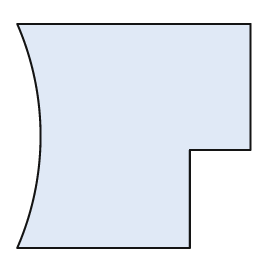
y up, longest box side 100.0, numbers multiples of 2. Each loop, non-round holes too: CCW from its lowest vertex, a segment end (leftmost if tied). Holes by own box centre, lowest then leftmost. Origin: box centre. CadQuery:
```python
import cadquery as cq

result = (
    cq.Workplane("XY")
    .moveTo(-50.0, -48.0)
    .lineTo(24.0, -48.0)
    .lineTo(24.0, -6.0)
    .lineTo(50.0, -6.0)
    .lineTo(50.0, 48.0)
    .lineTo(-50.0, 48.0)
    .threePointArc((-40.0, 0.0), (-50.0, -48.0))
    .close()
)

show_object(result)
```